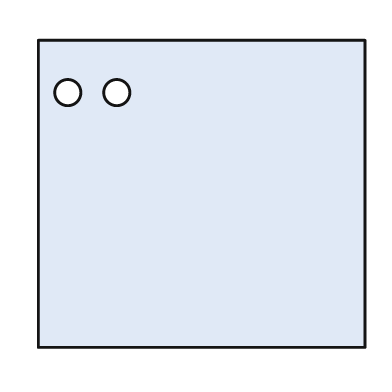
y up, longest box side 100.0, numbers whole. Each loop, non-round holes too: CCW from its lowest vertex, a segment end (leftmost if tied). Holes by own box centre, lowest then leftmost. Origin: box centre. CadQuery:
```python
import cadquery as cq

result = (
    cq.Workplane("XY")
    .moveTo(-50.0, -47.0)
    .lineTo(50.0, -47.0)
    .lineTo(50.0, 47.0)
    .lineTo(-50.0, 47.0)
    .close()
    .moveTo(-41.0, 31.0)
    .circle(4.0)
    .moveTo(-26.0, 31.0)
    .circle(4.0)
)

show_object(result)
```